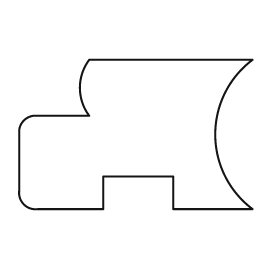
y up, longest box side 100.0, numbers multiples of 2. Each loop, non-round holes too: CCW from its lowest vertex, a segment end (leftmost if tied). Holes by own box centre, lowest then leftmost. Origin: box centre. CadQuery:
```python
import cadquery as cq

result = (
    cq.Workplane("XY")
    .moveTo(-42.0, -32.0)
    .lineTo(-14.0, -32.0)
    .lineTo(-14.0, -18.0)
    .lineTo(16.0, -18.0)
    .lineTo(16.0, -32.0)
    .lineTo(50.0, -32.0)
    .threePointArc((34.0, 0.0), (50.0, 32.0))
    .lineTo(-20.0, 32.0)
    .threePointArc((-24.0, 20.0), (-20.0, 8.0))
    .lineTo(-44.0, 8.0)
    .threePointArc((-48.0, 6.0), (-50.0, 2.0))
    .lineTo(-50.0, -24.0)
    .threePointArc((-48.0, -30.0), (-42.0, -32.0))
    .close()
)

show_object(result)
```